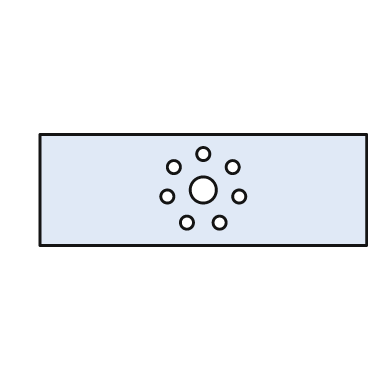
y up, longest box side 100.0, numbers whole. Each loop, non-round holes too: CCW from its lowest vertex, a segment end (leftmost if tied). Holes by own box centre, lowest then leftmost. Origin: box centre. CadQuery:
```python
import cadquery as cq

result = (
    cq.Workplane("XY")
    .moveTo(-50.0, -17.0)
    .lineTo(50.0, -17.0)
    .lineTo(50.0, 17.0)
    .lineTo(-50.0, 17.0)
    .close()
    .moveTo(-5.0, -10.0)
    .circle(2.0)
    .moveTo(5.0, -10.0)
    .circle(2.0)
    .moveTo(-11.0, -2.0)
    .circle(2.0)
    .moveTo(11.0, -2.0)
    .circle(2.0)
    .moveTo(0.0, 0.0)
    .circle(4.0)
    .moveTo(-9.0, 7.0)
    .circle(2.0)
    .moveTo(9.0, 7.0)
    .circle(2.0)
    .moveTo(0.0, 11.0)
    .circle(2.0)
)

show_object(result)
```